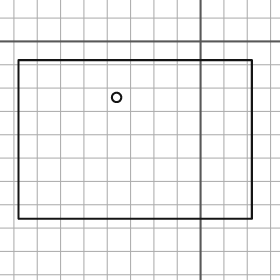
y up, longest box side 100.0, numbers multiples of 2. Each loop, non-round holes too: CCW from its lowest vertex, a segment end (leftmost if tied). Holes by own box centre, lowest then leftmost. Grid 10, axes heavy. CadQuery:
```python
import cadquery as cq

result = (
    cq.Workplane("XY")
    .moveTo(-78.0, -76.0)
    .lineTo(22.0, -76.0)
    .lineTo(22.0, -8.0)
    .lineTo(-78.0, -8.0)
    .close()
    .moveTo(-36.0, -24.0)
    .circle(2.0)
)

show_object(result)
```